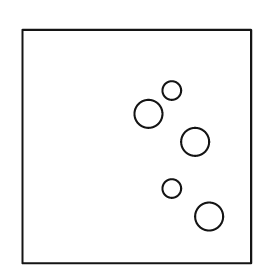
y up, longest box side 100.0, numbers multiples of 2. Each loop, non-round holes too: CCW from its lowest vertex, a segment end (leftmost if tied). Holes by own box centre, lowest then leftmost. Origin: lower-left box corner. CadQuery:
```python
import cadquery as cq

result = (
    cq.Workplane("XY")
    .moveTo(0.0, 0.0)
    .lineTo(98.0, 0.0)
    .lineTo(98.0, 100.0)
    .lineTo(0.0, 100.0)
    .close()
    .moveTo(80.0, 20.0)
    .circle(6.0)
    .moveTo(64.0, 32.0)
    .circle(4.0)
    .moveTo(74.0, 52.0)
    .circle(6.0)
    .moveTo(54.0, 64.0)
    .circle(6.0)
    .moveTo(64.0, 74.0)
    .circle(4.0)
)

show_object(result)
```